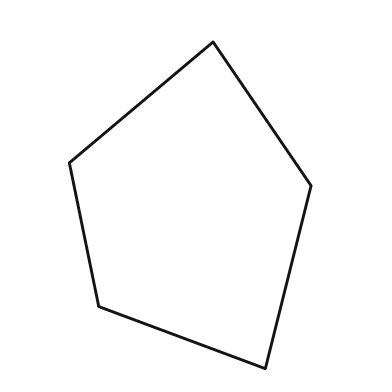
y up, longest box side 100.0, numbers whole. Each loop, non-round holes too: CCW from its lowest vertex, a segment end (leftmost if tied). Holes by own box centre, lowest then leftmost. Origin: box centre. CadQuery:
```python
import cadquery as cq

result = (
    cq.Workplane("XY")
    .moveTo(23.0, -50.0)
    .lineTo(37.0, 6.0)
    .lineTo(7.0, 50.0)
    .lineTo(-37.0, 13.0)
    .lineTo(-28.0, -31.0)
    .close()
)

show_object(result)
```